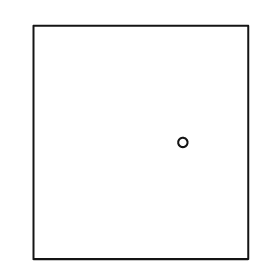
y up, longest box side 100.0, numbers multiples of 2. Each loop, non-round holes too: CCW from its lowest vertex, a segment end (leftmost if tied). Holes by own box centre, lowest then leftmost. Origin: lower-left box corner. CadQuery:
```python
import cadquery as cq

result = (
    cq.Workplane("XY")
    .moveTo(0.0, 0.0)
    .lineTo(92.0, 0.0)
    .lineTo(92.0, 100.0)
    .lineTo(0.0, 100.0)
    .close()
    .moveTo(64.0, 50.0)
    .circle(2.0)
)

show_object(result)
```